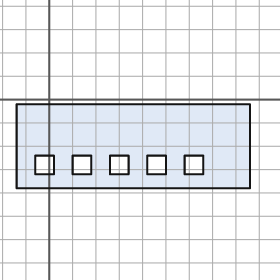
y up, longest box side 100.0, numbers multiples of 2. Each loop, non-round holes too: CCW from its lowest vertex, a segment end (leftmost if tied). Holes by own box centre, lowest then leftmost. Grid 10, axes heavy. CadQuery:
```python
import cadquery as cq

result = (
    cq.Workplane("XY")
    .moveTo(-14.0, -38.0)
    .lineTo(86.0, -38.0)
    .lineTo(86.0, -2.0)
    .lineTo(-14.0, -2.0)
    .close()
    .moveTo(-6.0, -32.0)
    .lineTo(2.0, -32.0)
    .lineTo(2.0, -24.0)
    .lineTo(-6.0, -24.0)
    .close()
    .moveTo(10.0, -32.0)
    .lineTo(18.0, -32.0)
    .lineTo(18.0, -24.0)
    .lineTo(10.0, -24.0)
    .close()
    .moveTo(26.0, -32.0)
    .lineTo(34.0, -32.0)
    .lineTo(34.0, -24.0)
    .lineTo(26.0, -24.0)
    .close()
    .moveTo(42.0, -32.0)
    .lineTo(50.0, -32.0)
    .lineTo(50.0, -24.0)
    .lineTo(42.0, -24.0)
    .close()
    .moveTo(58.0, -32.0)
    .lineTo(66.0, -32.0)
    .lineTo(66.0, -24.0)
    .lineTo(58.0, -24.0)
    .close()
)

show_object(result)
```